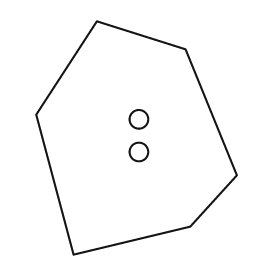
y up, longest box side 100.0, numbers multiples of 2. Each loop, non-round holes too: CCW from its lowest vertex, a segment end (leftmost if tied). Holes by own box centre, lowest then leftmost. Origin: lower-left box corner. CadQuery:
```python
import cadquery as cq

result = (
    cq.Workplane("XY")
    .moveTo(16.0, 0.0)
    .lineTo(66.0, 12.0)
    .lineTo(86.0, 34.0)
    .lineTo(64.0, 88.0)
    .lineTo(26.0, 100.0)
    .lineTo(0.0, 60.0)
    .close()
    .moveTo(44.0, 44.0)
    .circle(4.0)
    .moveTo(44.0, 58.0)
    .circle(4.0)
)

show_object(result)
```